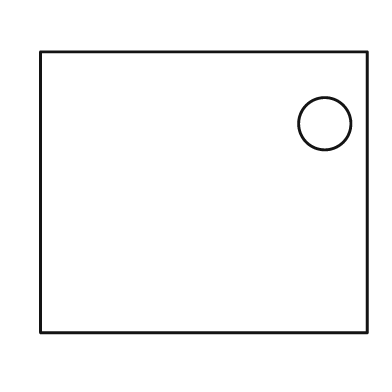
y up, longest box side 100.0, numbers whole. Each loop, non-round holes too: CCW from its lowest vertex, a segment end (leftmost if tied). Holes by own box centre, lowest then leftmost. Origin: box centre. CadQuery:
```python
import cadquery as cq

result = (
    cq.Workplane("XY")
    .moveTo(-50.0, -43.0)
    .lineTo(50.0, -43.0)
    .lineTo(50.0, 43.0)
    .lineTo(-50.0, 43.0)
    .close()
    .moveTo(37.0, 21.0)
    .circle(8.0)
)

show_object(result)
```